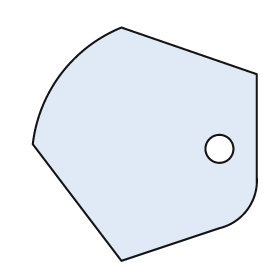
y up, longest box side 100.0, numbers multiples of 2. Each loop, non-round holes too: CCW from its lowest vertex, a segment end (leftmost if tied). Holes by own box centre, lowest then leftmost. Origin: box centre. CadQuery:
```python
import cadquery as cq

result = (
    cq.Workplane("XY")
    .moveTo(-10.0, -50.0)
    .lineTo(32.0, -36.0)
    .threePointArc((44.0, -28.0), (48.0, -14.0))
    .lineTo(48.0, 30.0)
    .lineTo(-10.0, 50.0)
    .threePointArc((-36.0, 30.0), (-48.0, 0.0))
    .close()
    .moveTo(32.0, -2.0)
    .circle(6.0)
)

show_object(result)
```